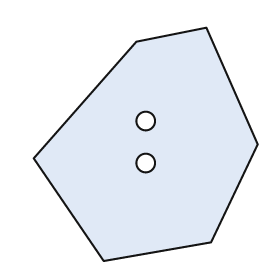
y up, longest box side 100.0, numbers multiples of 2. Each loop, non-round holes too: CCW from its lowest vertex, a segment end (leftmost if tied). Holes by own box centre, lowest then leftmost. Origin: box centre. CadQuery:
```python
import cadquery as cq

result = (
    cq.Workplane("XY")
    .moveTo(-18.0, -50.0)
    .lineTo(28.0, -42.0)
    .lineTo(48.0, 0.0)
    .lineTo(26.0, 50.0)
    .lineTo(-4.0, 44.0)
    .lineTo(-48.0, -6.0)
    .close()
    .moveTo(0.0, -8.0)
    .circle(4.0)
    .moveTo(0.0, 10.0)
    .circle(4.0)
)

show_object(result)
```